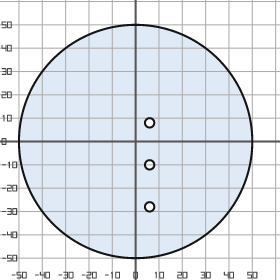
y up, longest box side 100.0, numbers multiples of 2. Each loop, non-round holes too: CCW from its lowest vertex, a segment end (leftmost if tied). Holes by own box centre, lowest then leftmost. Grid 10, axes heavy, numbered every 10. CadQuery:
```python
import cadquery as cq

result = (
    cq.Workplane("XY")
    .moveTo(0.0, 0.0)
    .circle(50.0)
    .moveTo(6.0, -28.0)
    .circle(2.0)
    .moveTo(6.0, -10.0)
    .circle(2.0)
    .moveTo(6.0, 8.0)
    .circle(2.0)
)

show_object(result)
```